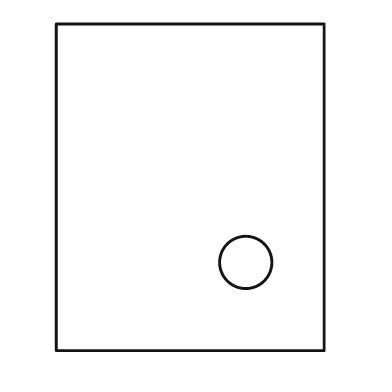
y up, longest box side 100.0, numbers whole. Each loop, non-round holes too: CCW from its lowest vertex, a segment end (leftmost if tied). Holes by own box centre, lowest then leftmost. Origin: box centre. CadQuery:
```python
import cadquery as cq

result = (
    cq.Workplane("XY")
    .moveTo(-41.0, -50.0)
    .lineTo(41.0, -50.0)
    .lineTo(41.0, 50.0)
    .lineTo(-41.0, 50.0)
    .close()
    .moveTo(17.0, -23.0)
    .circle(8.0)
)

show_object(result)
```